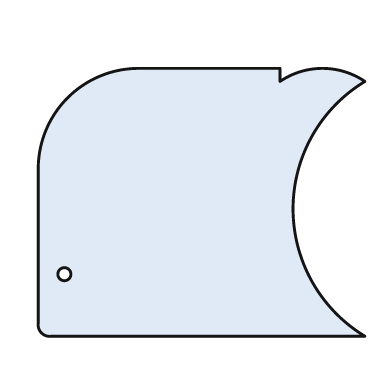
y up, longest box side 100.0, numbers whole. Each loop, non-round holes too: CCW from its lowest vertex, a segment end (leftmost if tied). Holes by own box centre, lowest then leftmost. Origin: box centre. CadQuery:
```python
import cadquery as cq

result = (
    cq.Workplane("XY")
    .moveTo(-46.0, -41.0)
    .lineTo(50.0, -41.0)
    .threePointArc((28.0, -2.0), (50.0, 37.0))
    .threePointArc((37.0, 41.0), (24.0, 37.0))
    .lineTo(24.0, 41.0)
    .lineTo(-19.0, 41.0)
    .threePointArc((-41.0, 32.0), (-50.0, 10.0))
    .lineTo(-50.0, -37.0)
    .threePointArc((-49.0, -40.0), (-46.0, -41.0))
    .close()
    .moveTo(-42.0, -22.0)
    .circle(2.0)
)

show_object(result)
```